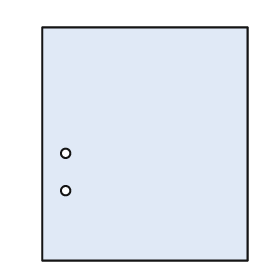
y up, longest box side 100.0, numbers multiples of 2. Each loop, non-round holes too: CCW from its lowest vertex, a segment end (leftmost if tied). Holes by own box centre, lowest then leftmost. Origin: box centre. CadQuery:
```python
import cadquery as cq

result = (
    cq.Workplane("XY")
    .moveTo(-44.0, -50.0)
    .lineTo(44.0, -50.0)
    .lineTo(44.0, 50.0)
    .lineTo(-44.0, 50.0)
    .close()
    .moveTo(-34.0, -20.0)
    .circle(2.0)
    .moveTo(-34.0, -4.0)
    .circle(2.0)
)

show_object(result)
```